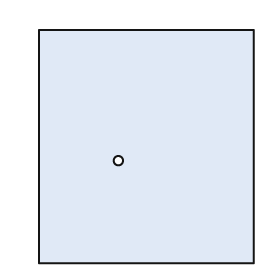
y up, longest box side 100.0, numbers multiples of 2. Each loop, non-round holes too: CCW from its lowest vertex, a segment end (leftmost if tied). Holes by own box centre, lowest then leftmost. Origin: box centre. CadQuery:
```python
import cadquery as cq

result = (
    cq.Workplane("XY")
    .moveTo(-46.0, -50.0)
    .lineTo(46.0, -50.0)
    .lineTo(46.0, 50.0)
    .lineTo(-46.0, 50.0)
    .close()
    .moveTo(-12.0, -6.0)
    .circle(2.0)
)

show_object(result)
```